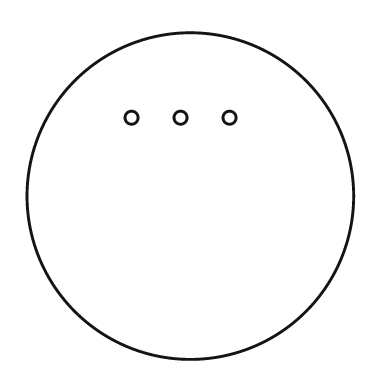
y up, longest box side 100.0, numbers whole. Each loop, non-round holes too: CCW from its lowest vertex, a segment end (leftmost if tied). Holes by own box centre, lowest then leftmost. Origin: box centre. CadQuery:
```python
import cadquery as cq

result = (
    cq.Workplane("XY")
    .moveTo(0.0, 0.0)
    .circle(50.0)
    .moveTo(-18.0, 24.0)
    .circle(2.0)
    .moveTo(-3.0, 24.0)
    .circle(2.0)
    .moveTo(12.0, 24.0)
    .circle(2.0)
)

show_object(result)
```